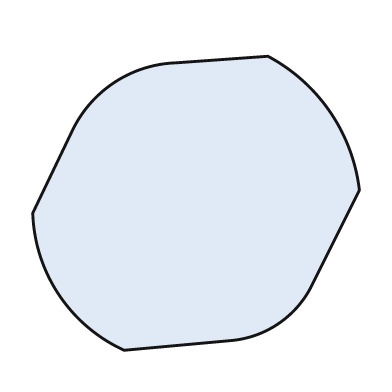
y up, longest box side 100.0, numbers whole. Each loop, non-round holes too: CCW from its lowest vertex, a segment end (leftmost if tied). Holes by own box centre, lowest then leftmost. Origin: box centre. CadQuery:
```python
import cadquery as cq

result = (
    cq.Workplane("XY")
    .moveTo(-22.0, -45.0)
    .lineTo(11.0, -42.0)
    .threePointArc((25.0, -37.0), (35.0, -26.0))
    .lineTo(50.0, 4.0)
    .threePointArc((41.0, 28.0), (22.0, 45.0))
    .lineTo(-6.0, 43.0)
    .threePointArc((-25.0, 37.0), (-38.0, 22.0))
    .lineTo(-50.0, -3.0)
    .threePointArc((-42.0, -28.0), (-22.0, -45.0))
    .close()
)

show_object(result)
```